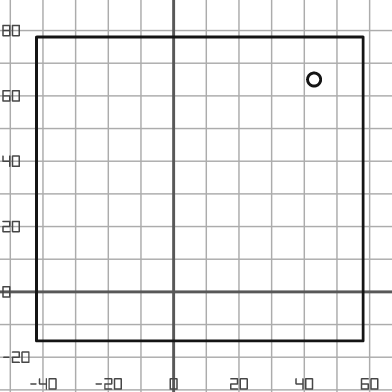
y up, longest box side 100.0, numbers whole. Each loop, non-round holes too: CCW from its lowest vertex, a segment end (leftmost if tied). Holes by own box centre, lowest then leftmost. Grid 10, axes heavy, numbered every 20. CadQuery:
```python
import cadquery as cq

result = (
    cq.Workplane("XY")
    .moveTo(-42.0, -15.0)
    .lineTo(58.0, -15.0)
    .lineTo(58.0, 78.0)
    .lineTo(-42.0, 78.0)
    .close()
    .moveTo(43.0, 65.0)
    .circle(2.0)
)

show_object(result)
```